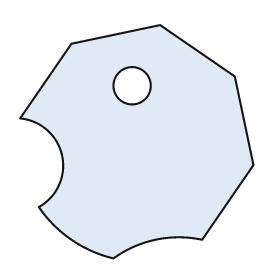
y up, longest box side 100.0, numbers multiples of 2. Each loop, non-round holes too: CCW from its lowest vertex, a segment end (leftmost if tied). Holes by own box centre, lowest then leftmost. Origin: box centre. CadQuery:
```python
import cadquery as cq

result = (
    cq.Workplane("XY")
    .moveTo(-10.0, -50.0)
    .threePointArc((8.0, -42.0), (28.0, -42.0))
    .lineTo(50.0, -10.0)
    .lineTo(42.0, 28.0)
    .lineTo(10.0, 50.0)
    .lineTo(-28.0, 42.0)
    .lineTo(-50.0, 10.0)
    .threePointArc((-32.0, -6.0), (-42.0, -28.0))
    .threePointArc((-28.0, -42.0), (-10.0, -50.0))
    .close()
    .moveTo(-2.0, 24.0)
    .circle(8.0)
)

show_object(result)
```